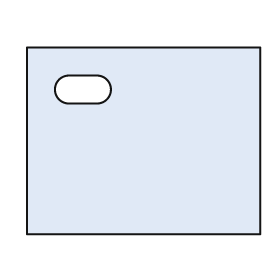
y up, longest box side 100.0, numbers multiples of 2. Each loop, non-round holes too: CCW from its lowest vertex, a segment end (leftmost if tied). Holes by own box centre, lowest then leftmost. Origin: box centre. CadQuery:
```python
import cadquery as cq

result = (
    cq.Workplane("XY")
    .moveTo(-50.0, -40.0)
    .lineTo(50.0, -40.0)
    .lineTo(50.0, 40.0)
    .lineTo(-50.0, 40.0)
    .close()
    .moveTo(-32.0, 16.0)
    .lineTo(-20.0, 16.0)
    .threePointArc((-14.0, 22.0), (-20.0, 28.0))
    .lineTo(-32.0, 28.0)
    .threePointArc((-38.0, 22.0), (-32.0, 16.0))
    .close()
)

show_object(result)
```